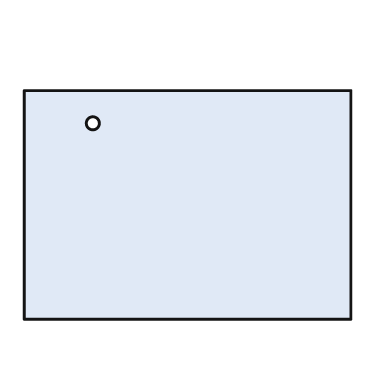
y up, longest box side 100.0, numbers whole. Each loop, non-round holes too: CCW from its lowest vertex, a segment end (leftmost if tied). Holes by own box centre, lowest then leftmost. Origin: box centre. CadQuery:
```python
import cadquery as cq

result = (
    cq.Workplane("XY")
    .moveTo(-50.0, -35.0)
    .lineTo(50.0, -35.0)
    .lineTo(50.0, 35.0)
    .lineTo(-50.0, 35.0)
    .close()
    .moveTo(-29.0, 25.0)
    .circle(2.0)
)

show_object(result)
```